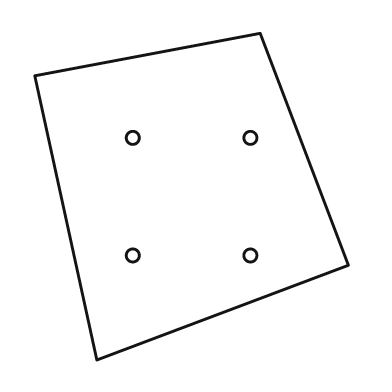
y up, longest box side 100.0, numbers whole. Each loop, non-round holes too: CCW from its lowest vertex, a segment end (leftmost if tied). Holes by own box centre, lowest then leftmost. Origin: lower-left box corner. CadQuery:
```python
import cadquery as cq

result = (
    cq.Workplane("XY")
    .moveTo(19.0, 0.0)
    .lineTo(96.0, 29.0)
    .lineTo(69.0, 100.0)
    .lineTo(0.0, 87.0)
    .close()
    .moveTo(30.0, 32.0)
    .circle(2.0)
    .moveTo(66.0, 32.0)
    .circle(2.0)
    .moveTo(30.0, 68.0)
    .circle(2.0)
    .moveTo(66.0, 68.0)
    .circle(2.0)
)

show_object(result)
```